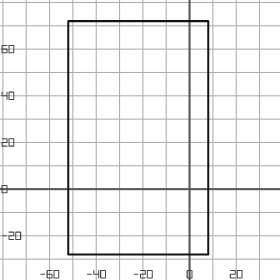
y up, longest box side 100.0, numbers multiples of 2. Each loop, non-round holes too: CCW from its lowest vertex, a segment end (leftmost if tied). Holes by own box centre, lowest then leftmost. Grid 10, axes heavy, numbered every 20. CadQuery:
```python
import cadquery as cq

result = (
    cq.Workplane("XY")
    .moveTo(-52.0, -28.0)
    .lineTo(8.0, -28.0)
    .lineTo(8.0, 72.0)
    .lineTo(-52.0, 72.0)
    .close()
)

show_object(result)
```